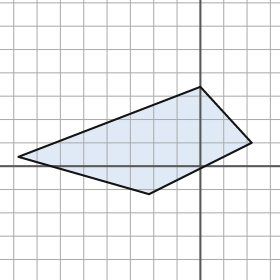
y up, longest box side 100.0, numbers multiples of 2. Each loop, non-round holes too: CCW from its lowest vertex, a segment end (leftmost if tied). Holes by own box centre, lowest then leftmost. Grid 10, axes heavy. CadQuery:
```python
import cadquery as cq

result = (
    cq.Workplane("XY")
    .moveTo(-22.0, -12.0)
    .lineTo(22.0, 10.0)
    .lineTo(0.0, 34.0)
    .lineTo(-78.0, 4.0)
    .close()
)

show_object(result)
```